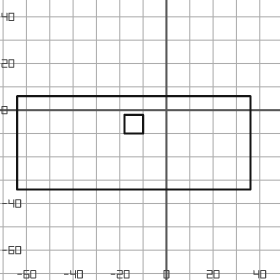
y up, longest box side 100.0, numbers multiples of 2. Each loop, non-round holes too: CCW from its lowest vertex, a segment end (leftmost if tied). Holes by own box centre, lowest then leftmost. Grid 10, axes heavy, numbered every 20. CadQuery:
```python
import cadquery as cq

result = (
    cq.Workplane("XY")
    .moveTo(-64.0, -34.0)
    .lineTo(36.0, -34.0)
    .lineTo(36.0, 6.0)
    .lineTo(-64.0, 6.0)
    .close()
    .moveTo(-18.0, -10.0)
    .lineTo(-10.0, -10.0)
    .lineTo(-10.0, -2.0)
    .lineTo(-18.0, -2.0)
    .close()
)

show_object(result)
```